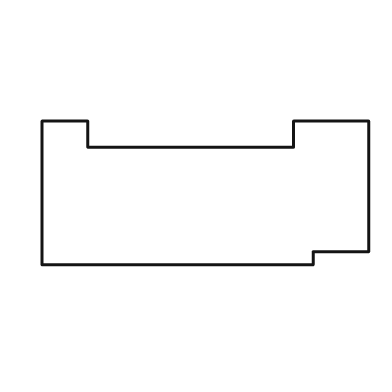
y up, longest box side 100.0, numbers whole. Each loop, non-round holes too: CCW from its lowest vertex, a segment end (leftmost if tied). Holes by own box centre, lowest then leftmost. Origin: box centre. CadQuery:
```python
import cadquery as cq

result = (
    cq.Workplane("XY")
    .moveTo(-50.0, -22.0)
    .lineTo(33.0, -22.0)
    .lineTo(33.0, -18.0)
    .lineTo(50.0, -18.0)
    .lineTo(50.0, 22.0)
    .lineTo(27.0, 22.0)
    .lineTo(27.0, 14.0)
    .lineTo(-36.0, 14.0)
    .lineTo(-36.0, 22.0)
    .lineTo(-50.0, 22.0)
    .close()
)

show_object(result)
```